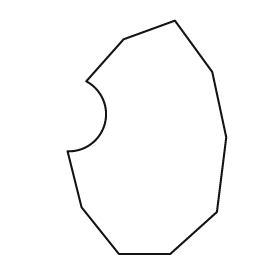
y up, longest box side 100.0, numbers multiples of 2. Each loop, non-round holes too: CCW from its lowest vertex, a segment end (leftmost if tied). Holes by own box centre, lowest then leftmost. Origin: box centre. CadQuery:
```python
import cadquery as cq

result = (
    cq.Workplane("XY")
    .moveTo(-12.0, -50.0)
    .lineTo(10.0, -50.0)
    .lineTo(30.0, -32.0)
    .lineTo(34.0, 0.0)
    .lineTo(28.0, 28.0)
    .lineTo(12.0, 50.0)
    .lineTo(-10.0, 42.0)
    .lineTo(-26.0, 24.0)
    .threePointArc((-18.0, 6.0), (-34.0, -6.0))
    .lineTo(-28.0, -30.0)
    .close()
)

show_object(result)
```